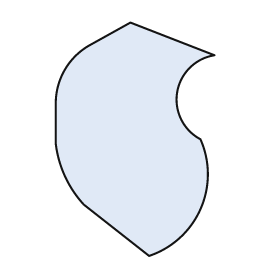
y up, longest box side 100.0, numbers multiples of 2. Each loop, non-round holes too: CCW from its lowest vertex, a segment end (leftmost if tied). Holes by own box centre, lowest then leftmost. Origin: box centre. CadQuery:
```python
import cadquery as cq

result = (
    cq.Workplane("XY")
    .moveTo(6.0, -50.0)
    .threePointArc((28.0, -30.0), (28.0, 0.0))
    .threePointArc((18.0, 20.0), (34.0, 36.0))
    .lineTo(-2.0, 50.0)
    .lineTo(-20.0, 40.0)
    .threePointArc((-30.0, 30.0), (-34.0, 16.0))
    .lineTo(-34.0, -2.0)
    .threePointArc((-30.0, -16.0), (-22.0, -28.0))
    .close()
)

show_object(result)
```